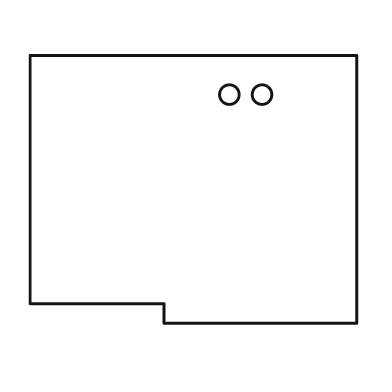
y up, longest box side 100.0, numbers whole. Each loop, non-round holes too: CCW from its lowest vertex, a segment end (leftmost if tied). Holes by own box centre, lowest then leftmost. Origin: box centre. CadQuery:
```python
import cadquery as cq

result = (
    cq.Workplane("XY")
    .moveTo(-9.0, -41.0)
    .lineTo(50.0, -41.0)
    .lineTo(50.0, 41.0)
    .lineTo(-50.0, 41.0)
    .lineTo(-50.0, -35.0)
    .lineTo(-9.0, -35.0)
    .close()
    .moveTo(11.0, 29.0)
    .circle(3.0)
    .moveTo(21.0, 29.0)
    .circle(3.0)
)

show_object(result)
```